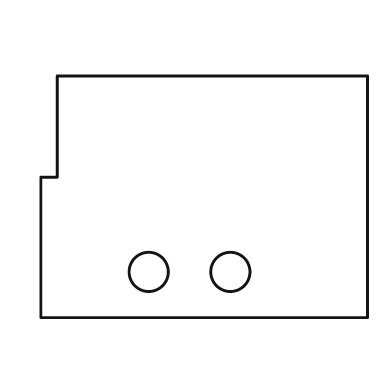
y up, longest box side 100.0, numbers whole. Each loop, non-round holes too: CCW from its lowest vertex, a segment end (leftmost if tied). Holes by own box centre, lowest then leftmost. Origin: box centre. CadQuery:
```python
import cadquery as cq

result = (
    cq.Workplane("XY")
    .moveTo(-50.0, -37.0)
    .lineTo(50.0, -37.0)
    .lineTo(50.0, 37.0)
    .lineTo(-45.0, 37.0)
    .lineTo(-45.0, 6.0)
    .lineTo(-50.0, 6.0)
    .close()
    .moveTo(-17.0, -23.0)
    .circle(6.0)
    .moveTo(8.0, -23.0)
    .circle(6.0)
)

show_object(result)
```